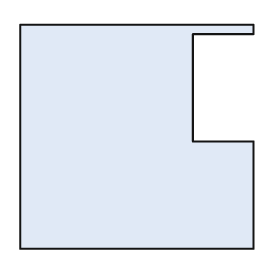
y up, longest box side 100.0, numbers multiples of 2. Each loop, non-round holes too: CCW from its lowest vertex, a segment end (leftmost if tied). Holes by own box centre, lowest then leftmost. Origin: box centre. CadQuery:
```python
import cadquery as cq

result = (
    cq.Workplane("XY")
    .moveTo(-50.0, -48.0)
    .lineTo(50.0, -48.0)
    .lineTo(50.0, -2.0)
    .lineTo(24.0, -2.0)
    .lineTo(24.0, 44.0)
    .lineTo(50.0, 44.0)
    .lineTo(50.0, 48.0)
    .lineTo(-50.0, 48.0)
    .close()
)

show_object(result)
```